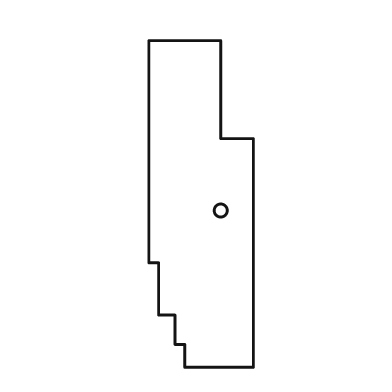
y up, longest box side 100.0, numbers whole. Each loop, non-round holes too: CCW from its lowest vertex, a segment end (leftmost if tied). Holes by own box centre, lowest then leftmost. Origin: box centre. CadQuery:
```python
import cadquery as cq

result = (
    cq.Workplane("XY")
    .moveTo(-5.0, -50.0)
    .lineTo(16.0, -50.0)
    .lineTo(16.0, 20.0)
    .lineTo(6.0, 20.0)
    .lineTo(6.0, 50.0)
    .lineTo(-16.0, 50.0)
    .lineTo(-16.0, -18.0)
    .lineTo(-13.0, -18.0)
    .lineTo(-13.0, -34.0)
    .lineTo(-8.0, -34.0)
    .lineTo(-8.0, -43.0)
    .lineTo(-5.0, -43.0)
    .close()
    .moveTo(6.0, -2.0)
    .circle(2.0)
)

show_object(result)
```